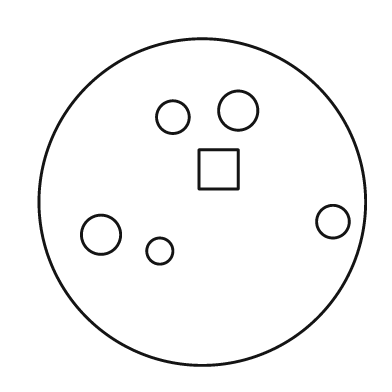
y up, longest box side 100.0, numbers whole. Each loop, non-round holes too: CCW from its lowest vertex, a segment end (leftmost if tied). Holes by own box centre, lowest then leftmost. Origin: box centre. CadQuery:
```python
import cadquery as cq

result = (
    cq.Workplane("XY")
    .moveTo(0.0, 0.0)
    .circle(50.0)
    .moveTo(-13.0, -15.0)
    .circle(4.0)
    .moveTo(-31.0, -10.0)
    .circle(6.0)
    .moveTo(40.0, -6.0)
    .circle(5.0)
    .moveTo(-1.0, 4.0)
    .lineTo(11.0, 4.0)
    .lineTo(11.0, 16.0)
    .lineTo(-1.0, 16.0)
    .close()
    .moveTo(-9.0, 26.0)
    .circle(5.0)
    .moveTo(11.0, 28.0)
    .circle(6.0)
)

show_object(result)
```